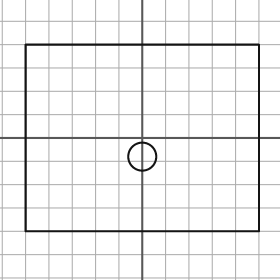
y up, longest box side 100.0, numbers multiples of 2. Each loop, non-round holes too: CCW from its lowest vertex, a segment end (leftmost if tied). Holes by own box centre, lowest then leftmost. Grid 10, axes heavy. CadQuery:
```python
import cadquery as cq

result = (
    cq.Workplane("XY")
    .moveTo(-50.0, -40.0)
    .lineTo(50.0, -40.0)
    .lineTo(50.0, 40.0)
    .lineTo(-50.0, 40.0)
    .close()
    .moveTo(0.0, -8.0)
    .circle(6.0)
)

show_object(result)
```